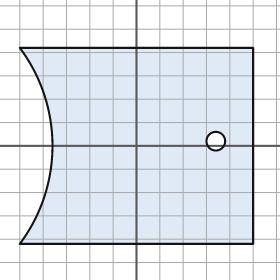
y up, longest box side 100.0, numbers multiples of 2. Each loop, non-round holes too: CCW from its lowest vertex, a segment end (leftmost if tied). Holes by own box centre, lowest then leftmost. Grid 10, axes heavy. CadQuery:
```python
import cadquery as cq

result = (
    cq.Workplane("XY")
    .moveTo(-50.0, -42.0)
    .lineTo(50.0, -42.0)
    .lineTo(50.0, 42.0)
    .lineTo(-50.0, 42.0)
    .threePointArc((-36.0, 0.0), (-50.0, -42.0))
    .close()
    .moveTo(34.0, 2.0)
    .circle(4.0)
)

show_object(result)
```